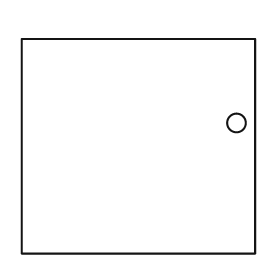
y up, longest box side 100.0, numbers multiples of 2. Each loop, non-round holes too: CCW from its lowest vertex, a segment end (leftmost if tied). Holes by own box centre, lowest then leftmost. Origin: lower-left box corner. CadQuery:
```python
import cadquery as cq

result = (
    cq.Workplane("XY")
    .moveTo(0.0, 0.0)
    .lineTo(100.0, 0.0)
    .lineTo(100.0, 92.0)
    .lineTo(0.0, 92.0)
    .close()
    .moveTo(92.0, 56.0)
    .circle(4.0)
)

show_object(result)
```